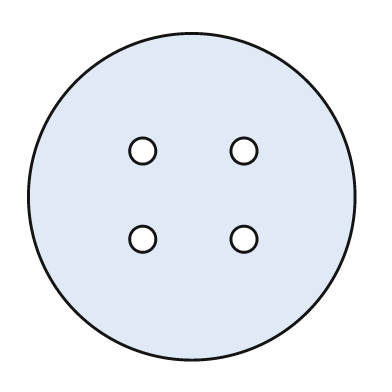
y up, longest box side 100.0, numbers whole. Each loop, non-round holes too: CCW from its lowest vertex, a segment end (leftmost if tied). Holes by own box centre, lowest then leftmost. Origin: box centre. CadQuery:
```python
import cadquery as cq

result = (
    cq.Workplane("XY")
    .moveTo(0.0, 0.0)
    .circle(50.0)
    .moveTo(-15.0, -13.0)
    .circle(4.0)
    .moveTo(16.0, -13.0)
    .circle(4.0)
    .moveTo(-15.0, 14.0)
    .circle(4.0)
    .moveTo(16.0, 14.0)
    .circle(4.0)
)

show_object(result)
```